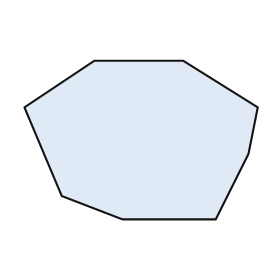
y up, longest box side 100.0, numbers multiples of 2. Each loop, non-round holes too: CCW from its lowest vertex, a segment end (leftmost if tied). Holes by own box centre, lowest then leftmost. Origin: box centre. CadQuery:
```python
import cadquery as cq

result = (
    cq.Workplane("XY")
    .moveTo(-8.0, -34.0)
    .lineTo(32.0, -34.0)
    .lineTo(46.0, -6.0)
    .lineTo(50.0, 14.0)
    .lineTo(18.0, 34.0)
    .lineTo(-20.0, 34.0)
    .lineTo(-50.0, 14.0)
    .lineTo(-34.0, -24.0)
    .close()
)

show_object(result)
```